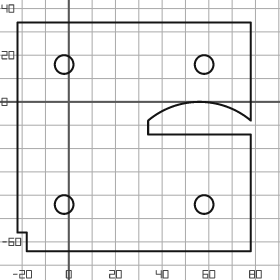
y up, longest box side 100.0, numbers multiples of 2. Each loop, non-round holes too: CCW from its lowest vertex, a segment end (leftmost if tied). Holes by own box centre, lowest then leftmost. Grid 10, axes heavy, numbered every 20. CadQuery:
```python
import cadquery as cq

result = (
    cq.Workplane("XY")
    .moveTo(-18.0, -64.0)
    .lineTo(78.0, -64.0)
    .lineTo(78.0, -14.0)
    .lineTo(34.0, -14.0)
    .lineTo(34.0, -8.0)
    .threePointArc((56.0, 0.0), (78.0, -8.0))
    .lineTo(78.0, 34.0)
    .lineTo(-22.0, 34.0)
    .lineTo(-22.0, -56.0)
    .lineTo(-18.0, -56.0)
    .close()
    .moveTo(-2.0, -44.0)
    .circle(4.0)
    .moveTo(58.0, -44.0)
    .circle(4.0)
    .moveTo(-2.0, 16.0)
    .circle(4.0)
    .moveTo(58.0, 16.0)
    .circle(4.0)
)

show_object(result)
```